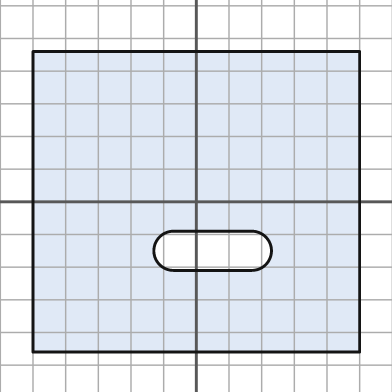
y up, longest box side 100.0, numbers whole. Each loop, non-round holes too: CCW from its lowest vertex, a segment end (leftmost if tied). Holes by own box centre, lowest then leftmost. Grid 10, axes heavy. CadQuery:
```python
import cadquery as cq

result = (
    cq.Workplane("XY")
    .moveTo(-50.0, -46.0)
    .lineTo(50.0, -46.0)
    .lineTo(50.0, 46.0)
    .lineTo(-50.0, 46.0)
    .close()
    .moveTo(-7.0, -21.0)
    .lineTo(17.0, -21.0)
    .threePointArc((23.0, -15.0), (17.0, -9.0))
    .lineTo(-7.0, -9.0)
    .threePointArc((-13.0, -15.0), (-7.0, -21.0))
    .close()
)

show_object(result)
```